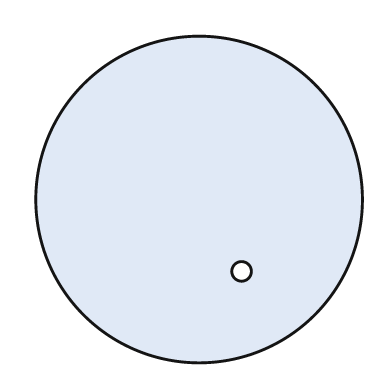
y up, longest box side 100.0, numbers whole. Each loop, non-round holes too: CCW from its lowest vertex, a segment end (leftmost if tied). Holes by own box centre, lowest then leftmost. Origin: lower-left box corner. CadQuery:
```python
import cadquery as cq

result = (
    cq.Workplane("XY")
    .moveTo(50.0, 50.0)
    .circle(50.0)
    .moveTo(63.0, 28.0)
    .circle(3.0)
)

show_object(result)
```